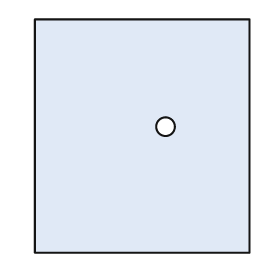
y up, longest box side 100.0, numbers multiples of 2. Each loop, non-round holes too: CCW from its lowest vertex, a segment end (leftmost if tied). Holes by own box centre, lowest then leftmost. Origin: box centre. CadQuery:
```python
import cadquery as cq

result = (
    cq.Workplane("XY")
    .moveTo(-46.0, -50.0)
    .lineTo(46.0, -50.0)
    .lineTo(46.0, 50.0)
    .lineTo(-46.0, 50.0)
    .close()
    .moveTo(10.0, 4.0)
    .circle(4.0)
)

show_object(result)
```